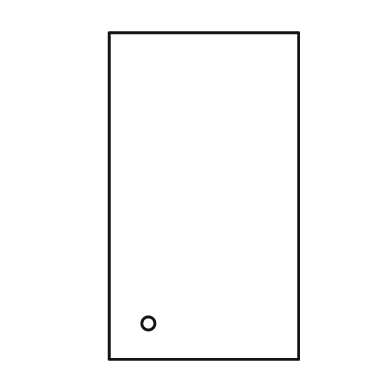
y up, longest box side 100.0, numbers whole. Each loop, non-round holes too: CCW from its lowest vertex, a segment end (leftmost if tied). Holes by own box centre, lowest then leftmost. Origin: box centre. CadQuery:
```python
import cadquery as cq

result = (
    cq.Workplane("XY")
    .moveTo(-29.0, -50.0)
    .lineTo(29.0, -50.0)
    .lineTo(29.0, 50.0)
    .lineTo(-29.0, 50.0)
    .close()
    .moveTo(-17.0, -39.0)
    .circle(2.0)
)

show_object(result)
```